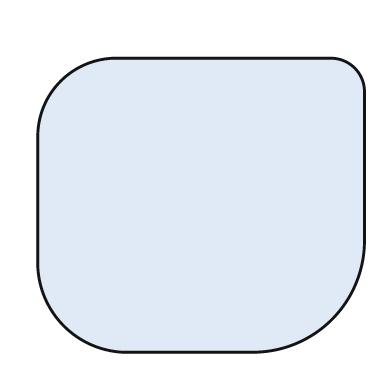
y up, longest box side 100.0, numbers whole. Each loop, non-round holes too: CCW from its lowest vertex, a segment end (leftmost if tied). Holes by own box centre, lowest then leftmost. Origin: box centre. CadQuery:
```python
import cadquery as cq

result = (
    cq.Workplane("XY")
    .moveTo(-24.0, -45.0)
    .lineTo(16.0, -45.0)
    .threePointArc((40.0, -35.0), (50.0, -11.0))
    .lineTo(50.0, 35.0)
    .threePointArc((47.0, 42.0), (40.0, 45.0))
    .lineTo(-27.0, 45.0)
    .threePointArc((-43.0, 38.0), (-50.0, 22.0))
    .lineTo(-50.0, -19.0)
    .threePointArc((-42.0, -37.0), (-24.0, -45.0))
    .close()
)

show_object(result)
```